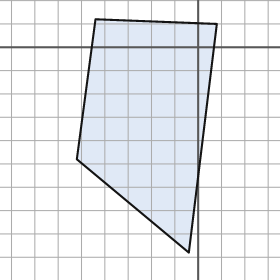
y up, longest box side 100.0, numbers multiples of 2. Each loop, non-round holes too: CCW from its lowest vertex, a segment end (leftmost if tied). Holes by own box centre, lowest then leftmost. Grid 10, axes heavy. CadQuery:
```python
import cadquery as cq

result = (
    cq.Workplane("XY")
    .moveTo(-4.0, -88.0)
    .lineTo(8.0, 10.0)
    .lineTo(-44.0, 12.0)
    .lineTo(-52.0, -48.0)
    .close()
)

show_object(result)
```